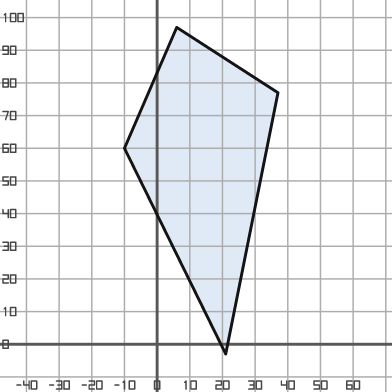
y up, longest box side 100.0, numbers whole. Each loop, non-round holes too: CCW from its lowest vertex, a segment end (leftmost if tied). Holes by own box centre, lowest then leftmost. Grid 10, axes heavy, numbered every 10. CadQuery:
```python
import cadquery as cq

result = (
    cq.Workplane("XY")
    .moveTo(21.0, -3.0)
    .lineTo(37.0, 77.0)
    .lineTo(6.0, 97.0)
    .lineTo(-10.0, 60.0)
    .close()
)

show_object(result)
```